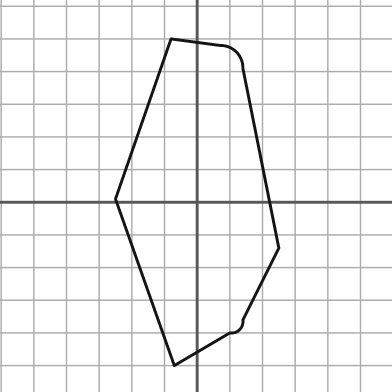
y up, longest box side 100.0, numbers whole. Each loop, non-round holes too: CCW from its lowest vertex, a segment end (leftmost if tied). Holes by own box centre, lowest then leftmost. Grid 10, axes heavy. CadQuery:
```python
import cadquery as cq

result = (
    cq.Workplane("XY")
    .moveTo(-7.0, -50.0)
    .lineTo(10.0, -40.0)
    .threePointArc((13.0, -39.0), (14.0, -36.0))
    .lineTo(25.0, -14.0)
    .lineTo(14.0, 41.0)
    .threePointArc((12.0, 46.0), (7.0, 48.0))
    .lineTo(-8.0, 50.0)
    .lineTo(-25.0, 1.0)
    .close()
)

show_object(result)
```